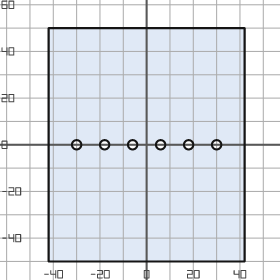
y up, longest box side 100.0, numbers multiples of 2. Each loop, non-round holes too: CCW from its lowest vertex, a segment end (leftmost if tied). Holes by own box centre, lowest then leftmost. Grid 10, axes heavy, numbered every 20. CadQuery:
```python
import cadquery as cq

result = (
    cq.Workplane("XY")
    .moveTo(-42.0, -50.0)
    .lineTo(42.0, -50.0)
    .lineTo(42.0, 50.0)
    .lineTo(-42.0, 50.0)
    .close()
    .moveTo(-30.0, 0.0)
    .circle(2.0)
    .moveTo(-18.0, 0.0)
    .circle(2.0)
    .moveTo(-6.0, 0.0)
    .circle(2.0)
    .moveTo(6.0, 0.0)
    .circle(2.0)
    .moveTo(18.0, 0.0)
    .circle(2.0)
    .moveTo(30.0, 0.0)
    .circle(2.0)
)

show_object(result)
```